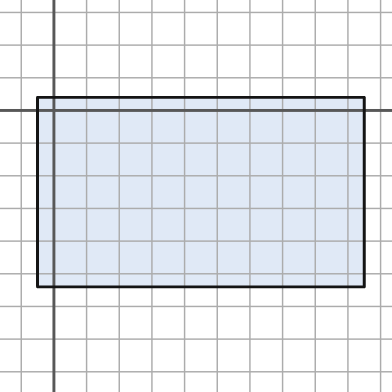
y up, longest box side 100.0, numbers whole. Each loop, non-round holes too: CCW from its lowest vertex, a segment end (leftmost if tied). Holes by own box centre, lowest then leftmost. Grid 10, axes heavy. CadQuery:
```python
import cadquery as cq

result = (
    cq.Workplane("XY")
    .moveTo(-5.0, -54.0)
    .lineTo(95.0, -54.0)
    .lineTo(95.0, 4.0)
    .lineTo(-5.0, 4.0)
    .close()
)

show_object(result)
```